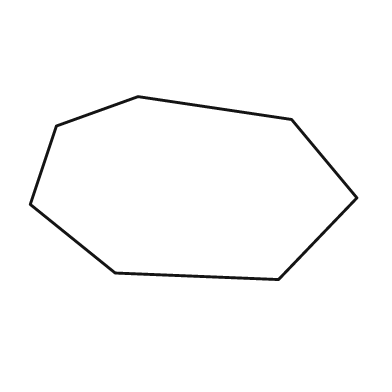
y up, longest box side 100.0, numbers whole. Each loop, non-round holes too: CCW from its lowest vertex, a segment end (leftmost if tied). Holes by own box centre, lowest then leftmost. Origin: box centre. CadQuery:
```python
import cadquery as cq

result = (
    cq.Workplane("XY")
    .moveTo(26.0, -28.0)
    .lineTo(50.0, -3.0)
    .lineTo(30.0, 21.0)
    .lineTo(-17.0, 28.0)
    .lineTo(-42.0, 19.0)
    .lineTo(-50.0, -5.0)
    .lineTo(-24.0, -26.0)
    .close()
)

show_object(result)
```